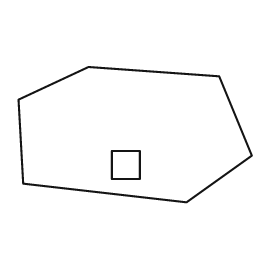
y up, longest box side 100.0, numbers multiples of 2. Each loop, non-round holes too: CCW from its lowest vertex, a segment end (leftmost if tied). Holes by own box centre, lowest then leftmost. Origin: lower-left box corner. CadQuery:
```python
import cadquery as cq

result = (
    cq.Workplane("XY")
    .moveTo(72.0, 0.0)
    .lineTo(100.0, 20.0)
    .lineTo(86.0, 54.0)
    .lineTo(30.0, 58.0)
    .lineTo(0.0, 44.0)
    .lineTo(2.0, 8.0)
    .close()
    .moveTo(40.0, 10.0)
    .lineTo(52.0, 10.0)
    .lineTo(52.0, 22.0)
    .lineTo(40.0, 22.0)
    .close()
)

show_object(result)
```